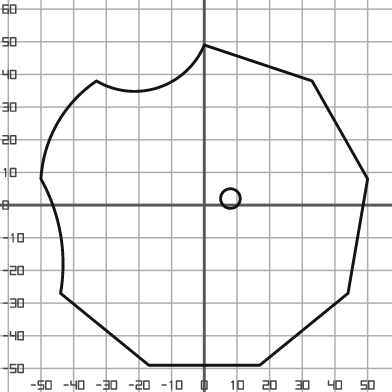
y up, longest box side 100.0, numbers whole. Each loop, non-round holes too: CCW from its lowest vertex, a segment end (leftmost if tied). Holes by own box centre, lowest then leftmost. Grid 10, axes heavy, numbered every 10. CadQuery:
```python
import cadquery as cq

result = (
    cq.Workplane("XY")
    .moveTo(-17.0, -49.0)
    .lineTo(17.0, -49.0)
    .lineTo(44.0, -27.0)
    .lineTo(50.0, 8.0)
    .lineTo(33.0, 38.0)
    .lineTo(0.0, 49.0)
    .threePointArc((-14.0, 36.0), (-33.0, 38.0))
    .threePointArc((-45.0, 25.0), (-50.0, 8.0))
    .threePointArc((-44.0, -9.0), (-44.0, -27.0))
    .close()
    .moveTo(8.0, 2.0)
    .circle(3.0)
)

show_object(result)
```